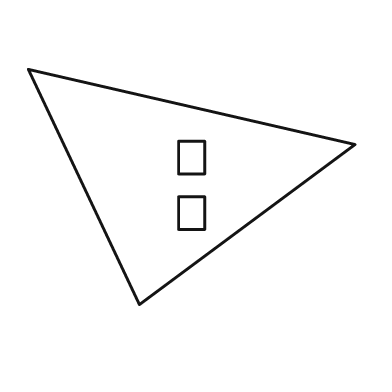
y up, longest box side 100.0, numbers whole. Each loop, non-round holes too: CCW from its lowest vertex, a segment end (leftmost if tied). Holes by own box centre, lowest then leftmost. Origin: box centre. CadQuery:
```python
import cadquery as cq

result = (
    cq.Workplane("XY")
    .moveTo(-16.0, -36.0)
    .lineTo(50.0, 13.0)
    .lineTo(-50.0, 36.0)
    .close()
    .moveTo(-4.0, -13.0)
    .lineTo(4.0, -13.0)
    .lineTo(4.0, -3.0)
    .lineTo(-4.0, -3.0)
    .close()
    .moveTo(-4.0, 4.0)
    .lineTo(4.0, 4.0)
    .lineTo(4.0, 14.0)
    .lineTo(-4.0, 14.0)
    .close()
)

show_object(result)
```